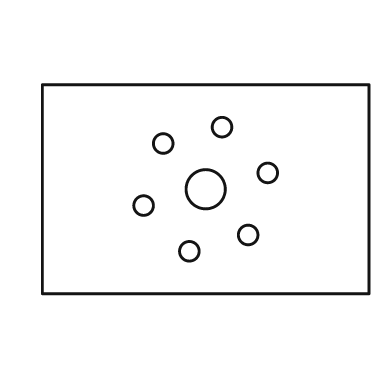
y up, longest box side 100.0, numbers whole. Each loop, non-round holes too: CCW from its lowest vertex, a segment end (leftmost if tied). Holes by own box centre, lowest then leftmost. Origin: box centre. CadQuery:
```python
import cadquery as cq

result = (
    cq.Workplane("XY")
    .moveTo(-50.0, -32.0)
    .lineTo(50.0, -32.0)
    .lineTo(50.0, 32.0)
    .lineTo(-50.0, 32.0)
    .close()
    .moveTo(-5.0, -19.0)
    .circle(3.0)
    .moveTo(13.0, -14.0)
    .circle(3.0)
    .moveTo(-19.0, -5.0)
    .circle(3.0)
    .moveTo(0.0, 0.0)
    .circle(6.0)
    .moveTo(19.0, 5.0)
    .circle(3.0)
    .moveTo(-13.0, 14.0)
    .circle(3.0)
    .moveTo(5.0, 19.0)
    .circle(3.0)
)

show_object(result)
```